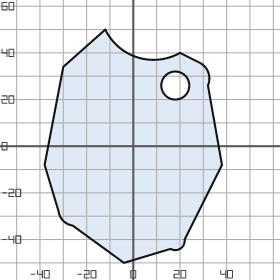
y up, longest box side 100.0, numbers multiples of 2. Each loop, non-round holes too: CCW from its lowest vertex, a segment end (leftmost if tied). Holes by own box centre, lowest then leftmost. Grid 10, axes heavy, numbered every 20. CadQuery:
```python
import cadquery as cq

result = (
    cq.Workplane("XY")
    .moveTo(-4.0, -50.0)
    .lineTo(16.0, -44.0)
    .threePointArc((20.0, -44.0), (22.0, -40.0))
    .lineTo(38.0, -8.0)
    .lineTo(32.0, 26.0)
    .threePointArc((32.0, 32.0), (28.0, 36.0))
    .lineTo(20.0, 40.0)
    .threePointArc((2.0, 38.0), (-12.0, 50.0))
    .lineTo(-30.0, 34.0)
    .lineTo(-38.0, -8.0)
    .lineTo(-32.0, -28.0)
    .threePointArc((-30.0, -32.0), (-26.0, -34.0))
    .close()
    .moveTo(18.0, 26.0)
    .circle(6.0)
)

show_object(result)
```